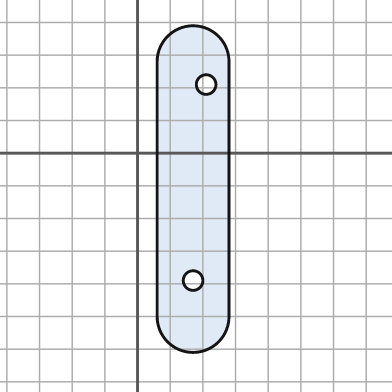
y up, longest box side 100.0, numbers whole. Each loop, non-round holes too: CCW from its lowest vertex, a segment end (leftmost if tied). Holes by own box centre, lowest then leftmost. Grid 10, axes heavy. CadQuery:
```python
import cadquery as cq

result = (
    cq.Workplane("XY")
    .moveTo(6.0, -50.0)
    .threePointArc((17.0, -61.0), (28.0, -50.0))
    .lineTo(28.0, 28.0)
    .threePointArc((17.0, 39.0), (6.0, 28.0))
    .close()
    .moveTo(17.0, -39.0)
    .circle(3.0)
    .moveTo(21.0, 21.0)
    .circle(3.0)
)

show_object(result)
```